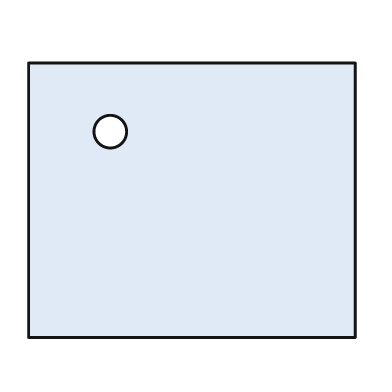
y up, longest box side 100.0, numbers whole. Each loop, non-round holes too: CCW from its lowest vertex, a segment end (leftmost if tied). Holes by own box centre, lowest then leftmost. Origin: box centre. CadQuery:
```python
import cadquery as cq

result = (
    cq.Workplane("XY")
    .moveTo(-50.0, -42.0)
    .lineTo(50.0, -42.0)
    .lineTo(50.0, 42.0)
    .lineTo(-50.0, 42.0)
    .close()
    .moveTo(-25.0, 21.0)
    .circle(5.0)
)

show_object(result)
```